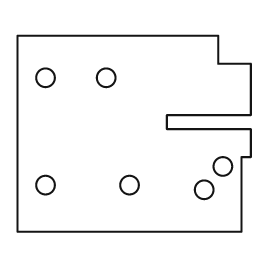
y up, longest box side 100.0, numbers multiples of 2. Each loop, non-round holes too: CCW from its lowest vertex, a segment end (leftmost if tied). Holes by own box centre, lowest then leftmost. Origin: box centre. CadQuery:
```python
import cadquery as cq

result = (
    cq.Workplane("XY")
    .moveTo(-50.0, -42.0)
    .lineTo(46.0, -42.0)
    .lineTo(46.0, -10.0)
    .lineTo(50.0, -10.0)
    .lineTo(50.0, 2.0)
    .lineTo(14.0, 2.0)
    .lineTo(14.0, 8.0)
    .lineTo(50.0, 8.0)
    .lineTo(50.0, 30.0)
    .lineTo(36.0, 30.0)
    .lineTo(36.0, 42.0)
    .lineTo(-50.0, 42.0)
    .close()
    .moveTo(30.0, -24.0)
    .circle(4.0)
    .moveTo(-38.0, -22.0)
    .circle(4.0)
    .moveTo(-2.0, -22.0)
    .circle(4.0)
    .moveTo(38.0, -14.0)
    .circle(4.0)
    .moveTo(-38.0, 24.0)
    .circle(4.0)
    .moveTo(-12.0, 24.0)
    .circle(4.0)
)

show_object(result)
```